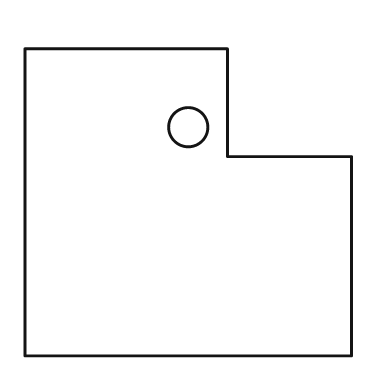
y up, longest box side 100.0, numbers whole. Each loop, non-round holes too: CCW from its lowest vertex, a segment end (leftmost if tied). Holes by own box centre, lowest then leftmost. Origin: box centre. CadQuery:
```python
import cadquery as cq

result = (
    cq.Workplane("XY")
    .moveTo(-50.0, -47.0)
    .lineTo(50.0, -47.0)
    .lineTo(50.0, 14.0)
    .lineTo(12.0, 14.0)
    .lineTo(12.0, 47.0)
    .lineTo(-50.0, 47.0)
    .close()
    .moveTo(0.0, 23.0)
    .circle(6.0)
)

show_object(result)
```